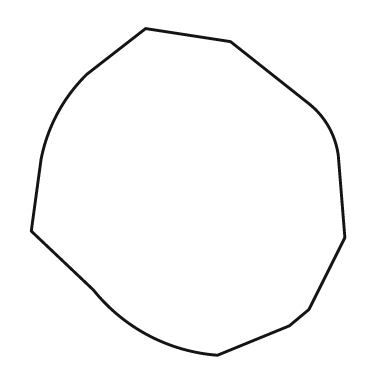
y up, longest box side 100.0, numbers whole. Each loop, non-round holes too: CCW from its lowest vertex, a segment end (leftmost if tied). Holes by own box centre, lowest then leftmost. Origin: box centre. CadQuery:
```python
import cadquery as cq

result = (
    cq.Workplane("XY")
    .moveTo(9.0, -50.0)
    .lineTo(31.0, -41.0)
    .lineTo(37.0, -36.0)
    .lineTo(48.0, -14.0)
    .lineTo(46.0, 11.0)
    .threePointArc((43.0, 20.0), (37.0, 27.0))
    .lineTo(13.0, 46.0)
    .lineTo(-13.0, 50.0)
    .lineTo(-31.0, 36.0)
    .threePointArc((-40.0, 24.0), (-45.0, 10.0))
    .lineTo(-48.0, -12.0)
    .lineTo(-29.0, -30.0)
    .threePointArc((-12.0, -44.0), (9.0, -50.0))
    .close()
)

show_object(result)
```